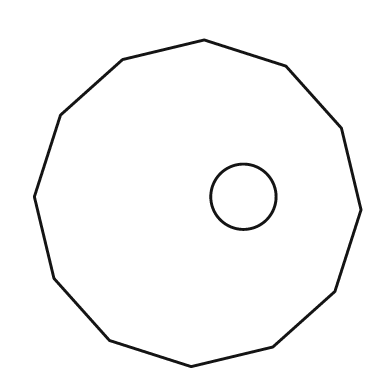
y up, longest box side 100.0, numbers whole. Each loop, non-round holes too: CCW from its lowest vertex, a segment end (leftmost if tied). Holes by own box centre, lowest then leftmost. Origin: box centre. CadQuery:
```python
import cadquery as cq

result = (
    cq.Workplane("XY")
    .moveTo(-2.0, -50.0)
    .lineTo(23.0, -44.0)
    .lineTo(42.0, -27.0)
    .lineTo(50.0, -2.0)
    .lineTo(44.0, 23.0)
    .lineTo(27.0, 42.0)
    .lineTo(2.0, 50.0)
    .lineTo(-23.0, 44.0)
    .lineTo(-42.0, 27.0)
    .lineTo(-50.0, 2.0)
    .lineTo(-44.0, -23.0)
    .lineTo(-27.0, -42.0)
    .close()
    .moveTo(14.0, 2.0)
    .circle(10.0)
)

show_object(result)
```